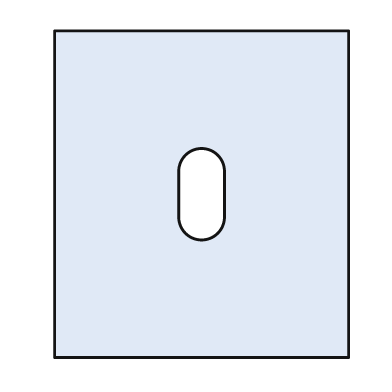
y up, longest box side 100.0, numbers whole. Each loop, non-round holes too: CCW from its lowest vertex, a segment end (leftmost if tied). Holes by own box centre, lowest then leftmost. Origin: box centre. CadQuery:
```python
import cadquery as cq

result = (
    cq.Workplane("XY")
    .moveTo(-45.0, -50.0)
    .lineTo(45.0, -50.0)
    .lineTo(45.0, 50.0)
    .lineTo(-45.0, 50.0)
    .close()
    .moveTo(-7.0, -7.0)
    .threePointArc((0.0, -14.0), (7.0, -7.0))
    .lineTo(7.0, 7.0)
    .threePointArc((0.0, 14.0), (-7.0, 7.0))
    .close()
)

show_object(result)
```